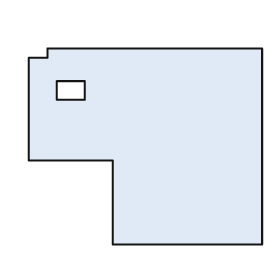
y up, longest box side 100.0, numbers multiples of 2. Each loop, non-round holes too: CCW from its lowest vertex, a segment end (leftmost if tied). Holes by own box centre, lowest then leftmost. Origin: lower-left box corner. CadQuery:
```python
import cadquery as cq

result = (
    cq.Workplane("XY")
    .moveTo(36.0, 0.0)
    .lineTo(100.0, 0.0)
    .lineTo(100.0, 84.0)
    .lineTo(8.0, 84.0)
    .lineTo(8.0, 80.0)
    .lineTo(0.0, 80.0)
    .lineTo(0.0, 36.0)
    .lineTo(36.0, 36.0)
    .close()
    .moveTo(12.0, 62.0)
    .lineTo(24.0, 62.0)
    .lineTo(24.0, 70.0)
    .lineTo(12.0, 70.0)
    .close()
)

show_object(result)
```